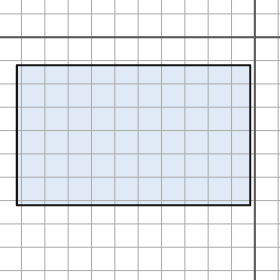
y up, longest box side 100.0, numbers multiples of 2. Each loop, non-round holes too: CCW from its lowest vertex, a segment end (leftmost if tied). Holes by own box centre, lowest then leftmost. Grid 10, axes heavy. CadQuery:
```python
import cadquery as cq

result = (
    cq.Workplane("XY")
    .moveTo(-102.0, -72.0)
    .lineTo(-2.0, -72.0)
    .lineTo(-2.0, -12.0)
    .lineTo(-102.0, -12.0)
    .close()
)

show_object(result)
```